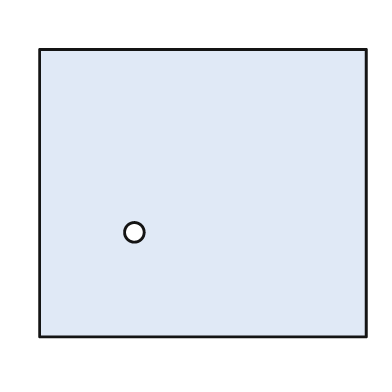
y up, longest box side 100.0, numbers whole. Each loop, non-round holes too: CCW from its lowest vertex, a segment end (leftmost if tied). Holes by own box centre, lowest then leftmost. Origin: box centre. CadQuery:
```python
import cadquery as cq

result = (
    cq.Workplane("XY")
    .moveTo(-50.0, -44.0)
    .lineTo(50.0, -44.0)
    .lineTo(50.0, 44.0)
    .lineTo(-50.0, 44.0)
    .close()
    .moveTo(-21.0, -12.0)
    .circle(3.0)
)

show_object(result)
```